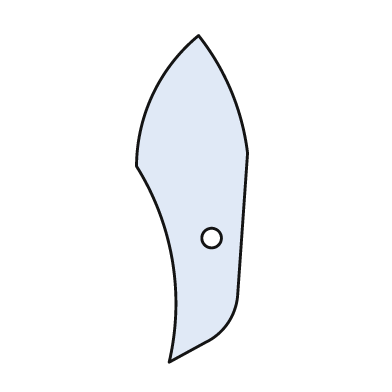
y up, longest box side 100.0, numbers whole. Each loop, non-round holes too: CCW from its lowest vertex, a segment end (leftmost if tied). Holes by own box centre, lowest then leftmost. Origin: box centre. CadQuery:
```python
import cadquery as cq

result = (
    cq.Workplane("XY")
    .moveTo(-7.0, -50.0)
    .lineTo(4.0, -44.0)
    .threePointArc((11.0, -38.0), (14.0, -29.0))
    .lineTo(17.0, 14.0)
    .threePointArc((12.0, 33.0), (2.0, 50.0))
    .threePointArc((-12.0, 32.0), (-17.0, 10.0))
    .threePointArc((-6.0, -19.0), (-7.0, -50.0))
    .close()
    .moveTo(6.0, -12.0)
    .circle(3.0)
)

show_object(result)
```